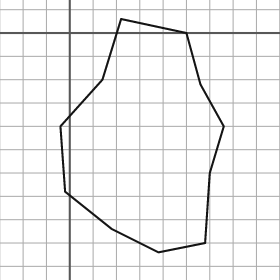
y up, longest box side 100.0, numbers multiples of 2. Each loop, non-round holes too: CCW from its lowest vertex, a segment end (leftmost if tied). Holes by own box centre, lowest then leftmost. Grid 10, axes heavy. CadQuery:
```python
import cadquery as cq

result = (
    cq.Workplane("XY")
    .moveTo(38.0, -94.0)
    .lineTo(58.0, -90.0)
    .lineTo(60.0, -60.0)
    .lineTo(66.0, -40.0)
    .lineTo(56.0, -22.0)
    .lineTo(50.0, 0.0)
    .lineTo(22.0, 6.0)
    .lineTo(14.0, -20.0)
    .lineTo(-4.0, -40.0)
    .lineTo(-2.0, -68.0)
    .lineTo(18.0, -84.0)
    .close()
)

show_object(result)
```